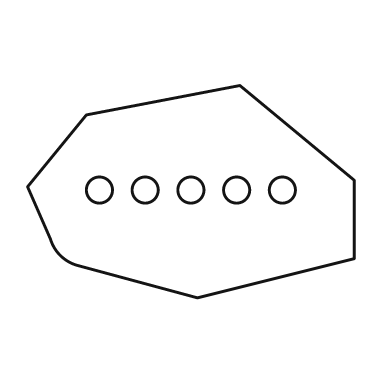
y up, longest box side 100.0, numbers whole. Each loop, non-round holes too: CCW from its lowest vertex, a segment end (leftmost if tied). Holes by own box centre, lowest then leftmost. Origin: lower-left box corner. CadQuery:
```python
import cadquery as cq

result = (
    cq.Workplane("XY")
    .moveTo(52.0, 0.0)
    .lineTo(100.0, 12.0)
    .lineTo(100.0, 36.0)
    .lineTo(65.0, 65.0)
    .lineTo(18.0, 56.0)
    .lineTo(0.0, 34.0)
    .lineTo(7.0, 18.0)
    .threePointArc((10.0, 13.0), (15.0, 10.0))
    .close()
    .moveTo(22.0, 33.0)
    .circle(4.0)
    .moveTo(36.0, 33.0)
    .circle(4.0)
    .moveTo(50.0, 33.0)
    .circle(4.0)
    .moveTo(64.0, 33.0)
    .circle(4.0)
    .moveTo(78.0, 33.0)
    .circle(4.0)
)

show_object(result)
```